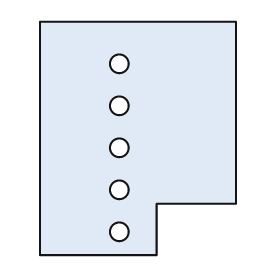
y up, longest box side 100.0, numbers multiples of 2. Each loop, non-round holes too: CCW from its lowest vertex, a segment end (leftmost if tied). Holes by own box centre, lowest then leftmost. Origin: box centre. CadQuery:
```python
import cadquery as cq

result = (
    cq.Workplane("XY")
    .moveTo(-42.0, -50.0)
    .lineTo(8.0, -50.0)
    .lineTo(8.0, -28.0)
    .lineTo(42.0, -28.0)
    .lineTo(42.0, 50.0)
    .lineTo(-42.0, 50.0)
    .close()
    .moveTo(-8.0, -40.0)
    .circle(4.0)
    .moveTo(-8.0, -22.0)
    .circle(4.0)
    .moveTo(-8.0, -4.0)
    .circle(4.0)
    .moveTo(-8.0, 14.0)
    .circle(4.0)
    .moveTo(-8.0, 32.0)
    .circle(4.0)
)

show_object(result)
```